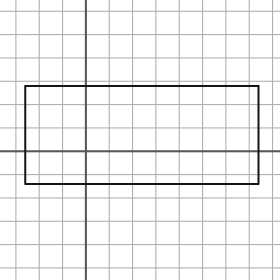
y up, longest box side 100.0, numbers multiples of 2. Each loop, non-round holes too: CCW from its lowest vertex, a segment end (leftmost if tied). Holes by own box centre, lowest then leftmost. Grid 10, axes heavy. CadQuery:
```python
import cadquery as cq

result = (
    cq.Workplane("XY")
    .moveTo(-26.0, -14.0)
    .lineTo(74.0, -14.0)
    .lineTo(74.0, 28.0)
    .lineTo(-26.0, 28.0)
    .close()
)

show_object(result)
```